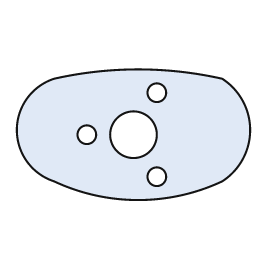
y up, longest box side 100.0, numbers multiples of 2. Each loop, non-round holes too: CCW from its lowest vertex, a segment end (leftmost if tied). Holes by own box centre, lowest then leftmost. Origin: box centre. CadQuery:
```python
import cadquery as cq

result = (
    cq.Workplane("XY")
    .moveTo(-34.0, -20.0)
    .threePointArc((2.0, -28.0), (38.0, -20.0))
    .threePointArc((50.0, 2.0), (38.0, 24.0))
    .threePointArc((2.0, 28.0), (-34.0, 24.0))
    .threePointArc((-50.0, 2.0), (-34.0, -20.0))
    .close()
    .moveTo(10.0, -18.0)
    .circle(4.0)
    .moveTo(-20.0, 0.0)
    .circle(4.0)
    .moveTo(0.0, 0.0)
    .circle(10.0)
    .moveTo(10.0, 18.0)
    .circle(4.0)
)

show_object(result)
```